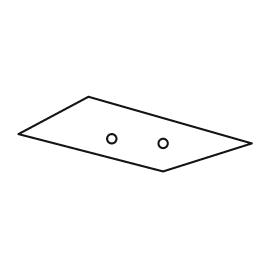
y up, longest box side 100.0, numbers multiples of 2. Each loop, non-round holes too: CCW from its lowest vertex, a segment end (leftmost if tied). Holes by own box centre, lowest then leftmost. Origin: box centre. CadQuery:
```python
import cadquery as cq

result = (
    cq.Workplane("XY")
    .moveTo(12.0, -16.0)
    .lineTo(50.0, -4.0)
    .lineTo(-20.0, 16.0)
    .lineTo(-50.0, 0.0)
    .close()
    .moveTo(12.0, -4.0)
    .circle(2.0)
    .moveTo(-10.0, -2.0)
    .circle(2.0)
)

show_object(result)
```